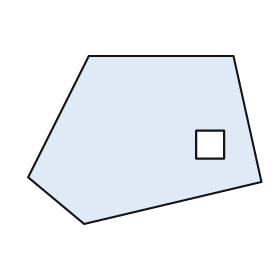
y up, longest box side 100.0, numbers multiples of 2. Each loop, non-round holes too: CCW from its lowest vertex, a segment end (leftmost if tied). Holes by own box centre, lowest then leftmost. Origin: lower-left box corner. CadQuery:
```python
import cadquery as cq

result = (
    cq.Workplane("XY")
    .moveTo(24.0, 0.0)
    .lineTo(100.0, 18.0)
    .lineTo(88.0, 72.0)
    .lineTo(26.0, 72.0)
    .lineTo(0.0, 20.0)
    .close()
    .moveTo(72.0, 28.0)
    .lineTo(84.0, 28.0)
    .lineTo(84.0, 40.0)
    .lineTo(72.0, 40.0)
    .close()
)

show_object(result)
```